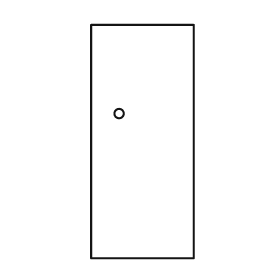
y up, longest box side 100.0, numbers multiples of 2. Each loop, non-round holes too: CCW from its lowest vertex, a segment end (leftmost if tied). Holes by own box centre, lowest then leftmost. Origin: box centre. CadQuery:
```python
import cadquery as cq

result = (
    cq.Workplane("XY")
    .moveTo(-22.0, -50.0)
    .lineTo(22.0, -50.0)
    .lineTo(22.0, 50.0)
    .lineTo(-22.0, 50.0)
    .close()
    .moveTo(-10.0, 12.0)
    .circle(2.0)
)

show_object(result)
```